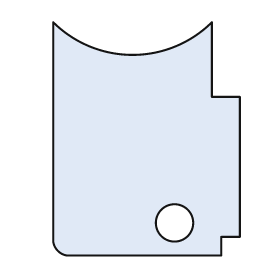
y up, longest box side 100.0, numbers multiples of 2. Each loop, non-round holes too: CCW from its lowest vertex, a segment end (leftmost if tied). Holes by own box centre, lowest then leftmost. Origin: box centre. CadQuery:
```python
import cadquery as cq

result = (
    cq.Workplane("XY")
    .moveTo(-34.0, -50.0)
    .lineTo(32.0, -50.0)
    .lineTo(32.0, -42.0)
    .lineTo(40.0, -42.0)
    .lineTo(40.0, 18.0)
    .lineTo(28.0, 18.0)
    .lineTo(28.0, 50.0)
    .threePointArc((-6.0, 36.0), (-40.0, 50.0))
    .lineTo(-40.0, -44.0)
    .threePointArc((-38.0, -48.0), (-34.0, -50.0))
    .close()
    .moveTo(12.0, -36.0)
    .circle(8.0)
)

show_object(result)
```